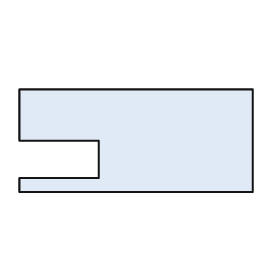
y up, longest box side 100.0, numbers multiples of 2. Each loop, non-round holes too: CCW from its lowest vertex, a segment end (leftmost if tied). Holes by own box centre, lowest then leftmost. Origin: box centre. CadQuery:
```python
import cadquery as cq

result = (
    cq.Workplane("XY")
    .moveTo(-50.0, -22.0)
    .lineTo(50.0, -22.0)
    .lineTo(50.0, 22.0)
    .lineTo(-50.0, 22.0)
    .lineTo(-50.0, 0.0)
    .lineTo(-16.0, 0.0)
    .lineTo(-16.0, -16.0)
    .lineTo(-50.0, -16.0)
    .close()
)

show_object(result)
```